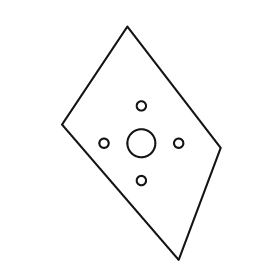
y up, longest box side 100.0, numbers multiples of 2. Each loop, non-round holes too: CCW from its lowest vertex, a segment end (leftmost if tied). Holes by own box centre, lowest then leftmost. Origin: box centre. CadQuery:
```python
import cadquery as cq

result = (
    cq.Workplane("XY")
    .moveTo(16.0, -50.0)
    .lineTo(34.0, -2.0)
    .lineTo(-6.0, 50.0)
    .lineTo(-34.0, 8.0)
    .close()
    .moveTo(0.0, -16.0)
    .circle(2.0)
    .moveTo(-16.0, 0.0)
    .circle(2.0)
    .moveTo(0.0, 0.0)
    .circle(6.0)
    .moveTo(16.0, 0.0)
    .circle(2.0)
    .moveTo(0.0, 16.0)
    .circle(2.0)
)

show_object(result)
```